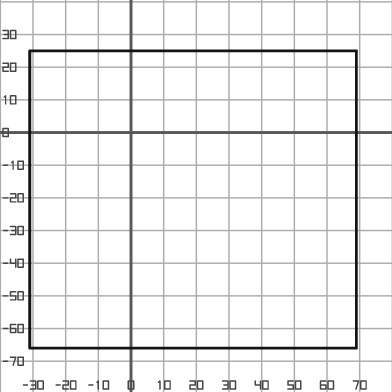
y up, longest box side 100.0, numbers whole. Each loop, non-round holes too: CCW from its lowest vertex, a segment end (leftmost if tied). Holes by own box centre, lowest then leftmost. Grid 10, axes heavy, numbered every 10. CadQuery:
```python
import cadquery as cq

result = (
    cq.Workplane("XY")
    .moveTo(-31.0, -66.0)
    .lineTo(69.0, -66.0)
    .lineTo(69.0, 25.0)
    .lineTo(-31.0, 25.0)
    .close()
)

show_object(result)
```